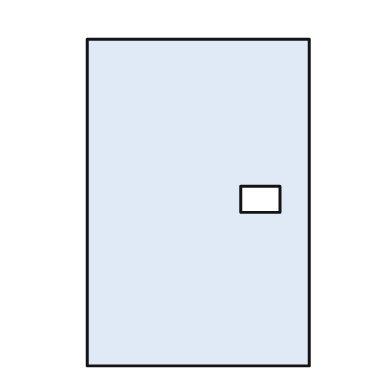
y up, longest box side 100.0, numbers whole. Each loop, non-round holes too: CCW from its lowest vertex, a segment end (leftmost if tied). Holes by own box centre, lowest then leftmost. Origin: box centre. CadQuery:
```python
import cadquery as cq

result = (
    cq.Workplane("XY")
    .moveTo(-34.0, -50.0)
    .lineTo(34.0, -50.0)
    .lineTo(34.0, 50.0)
    .lineTo(-34.0, 50.0)
    .close()
    .moveTo(13.0, -3.0)
    .lineTo(25.0, -3.0)
    .lineTo(25.0, 5.0)
    .lineTo(13.0, 5.0)
    .close()
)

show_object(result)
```